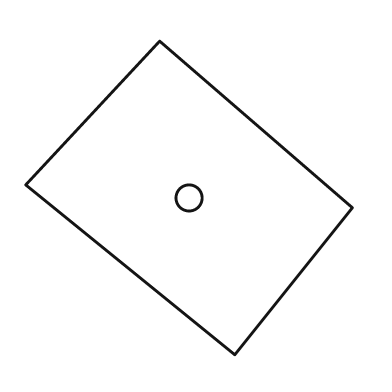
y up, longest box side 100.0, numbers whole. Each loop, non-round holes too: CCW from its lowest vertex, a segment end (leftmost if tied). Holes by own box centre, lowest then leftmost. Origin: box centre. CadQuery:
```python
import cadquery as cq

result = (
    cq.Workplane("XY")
    .moveTo(14.0, -48.0)
    .lineTo(50.0, -3.0)
    .lineTo(-9.0, 48.0)
    .lineTo(-50.0, 4.0)
    .close()
    .moveTo(0.0, 0.0)
    .circle(4.0)
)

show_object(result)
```